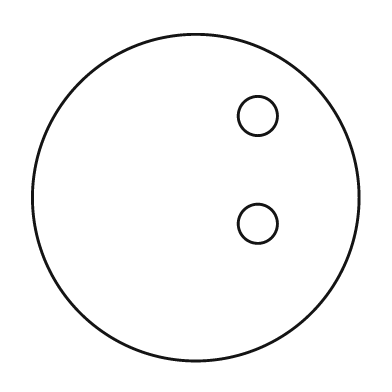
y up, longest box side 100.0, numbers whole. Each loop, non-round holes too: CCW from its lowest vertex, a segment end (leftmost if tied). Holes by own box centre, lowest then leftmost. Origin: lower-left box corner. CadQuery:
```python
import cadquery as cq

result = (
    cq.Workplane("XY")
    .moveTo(50.0, 50.0)
    .circle(50.0)
    .moveTo(69.0, 42.0)
    .circle(6.0)
    .moveTo(69.0, 75.0)
    .circle(6.0)
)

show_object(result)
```